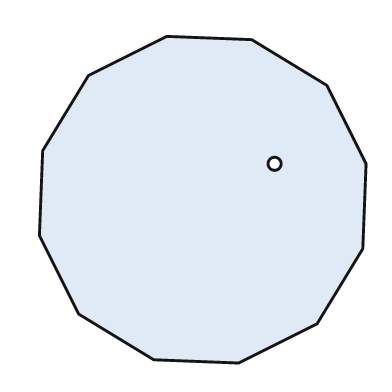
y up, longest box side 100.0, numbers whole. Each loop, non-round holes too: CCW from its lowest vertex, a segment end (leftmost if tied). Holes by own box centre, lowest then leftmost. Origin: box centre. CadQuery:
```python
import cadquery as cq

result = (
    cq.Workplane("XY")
    .moveTo(11.0, -50.0)
    .lineTo(35.0, -38.0)
    .lineTo(49.0, -15.0)
    .lineTo(50.0, 11.0)
    .lineTo(38.0, 35.0)
    .lineTo(15.0, 49.0)
    .lineTo(-11.0, 50.0)
    .lineTo(-35.0, 38.0)
    .lineTo(-49.0, 15.0)
    .lineTo(-50.0, -11.0)
    .lineTo(-38.0, -35.0)
    .lineTo(-15.0, -49.0)
    .close()
    .moveTo(22.0, 11.0)
    .circle(2.0)
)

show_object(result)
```